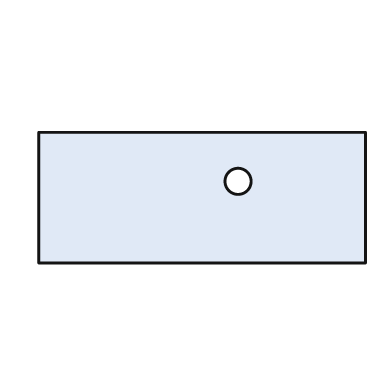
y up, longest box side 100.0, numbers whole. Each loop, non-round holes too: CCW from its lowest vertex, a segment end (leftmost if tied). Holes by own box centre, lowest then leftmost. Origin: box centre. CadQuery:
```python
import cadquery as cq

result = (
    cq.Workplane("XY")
    .moveTo(-50.0, -20.0)
    .lineTo(50.0, -20.0)
    .lineTo(50.0, 20.0)
    .lineTo(-50.0, 20.0)
    .close()
    .moveTo(11.0, 5.0)
    .circle(4.0)
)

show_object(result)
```